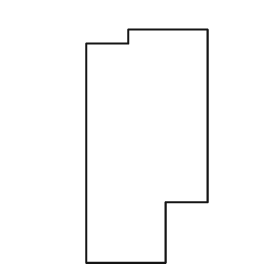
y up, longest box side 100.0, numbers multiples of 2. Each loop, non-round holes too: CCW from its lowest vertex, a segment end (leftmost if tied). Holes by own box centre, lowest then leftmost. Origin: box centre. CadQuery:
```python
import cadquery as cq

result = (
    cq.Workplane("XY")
    .moveTo(-26.0, -50.0)
    .lineTo(8.0, -50.0)
    .lineTo(8.0, -24.0)
    .lineTo(26.0, -24.0)
    .lineTo(26.0, 50.0)
    .lineTo(-8.0, 50.0)
    .lineTo(-8.0, 44.0)
    .lineTo(-26.0, 44.0)
    .close()
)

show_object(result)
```